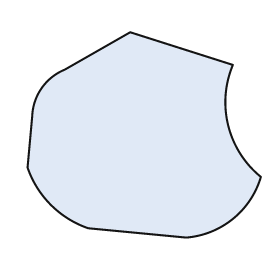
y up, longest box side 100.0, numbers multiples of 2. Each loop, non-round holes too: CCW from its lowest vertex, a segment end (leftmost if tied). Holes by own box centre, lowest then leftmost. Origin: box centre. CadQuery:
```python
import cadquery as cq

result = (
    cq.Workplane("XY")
    .moveTo(18.0, -44.0)
    .threePointArc((38.0, -36.0), (50.0, -18.0))
    .threePointArc((36.0, 4.0), (38.0, 30.0))
    .lineTo(-6.0, 44.0)
    .lineTo(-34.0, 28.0)
    .threePointArc((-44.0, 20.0), (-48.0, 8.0))
    .lineTo(-50.0, -14.0)
    .threePointArc((-40.0, -30.0), (-24.0, -40.0))
    .close()
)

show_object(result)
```